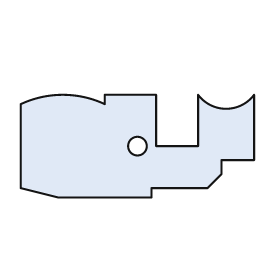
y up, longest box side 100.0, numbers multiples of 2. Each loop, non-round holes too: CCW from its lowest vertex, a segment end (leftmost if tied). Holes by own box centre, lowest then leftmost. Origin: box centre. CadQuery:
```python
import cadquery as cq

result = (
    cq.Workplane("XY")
    .moveTo(-34.0, -22.0)
    .lineTo(6.0, -22.0)
    .lineTo(6.0, -18.0)
    .lineTo(30.0, -18.0)
    .lineTo(36.0, -12.0)
    .lineTo(36.0, -6.0)
    .lineTo(50.0, -6.0)
    .lineTo(50.0, 22.0)
    .threePointArc((38.0, 16.0), (26.0, 22.0))
    .lineTo(26.0, 0.0)
    .lineTo(8.0, 0.0)
    .lineTo(8.0, 22.0)
    .lineTo(-14.0, 22.0)
    .lineTo(-14.0, 18.0)
    .threePointArc((-32.0, 22.0), (-50.0, 18.0))
    .lineTo(-50.0, -18.0)
    .close()
    .moveTo(0.0, 0.0)
    .circle(4.0)
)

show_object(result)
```